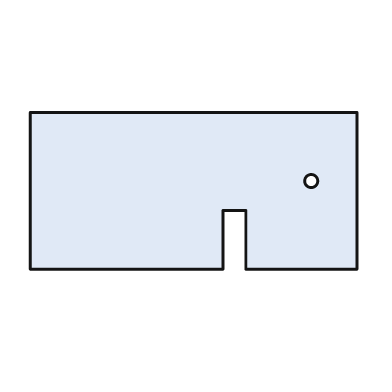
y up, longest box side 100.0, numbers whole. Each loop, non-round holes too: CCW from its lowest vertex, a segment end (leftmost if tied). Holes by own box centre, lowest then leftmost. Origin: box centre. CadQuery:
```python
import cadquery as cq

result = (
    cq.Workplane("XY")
    .moveTo(-50.0, -24.0)
    .lineTo(9.0, -24.0)
    .lineTo(9.0, -6.0)
    .lineTo(16.0, -6.0)
    .lineTo(16.0, -24.0)
    .lineTo(50.0, -24.0)
    .lineTo(50.0, 24.0)
    .lineTo(-50.0, 24.0)
    .close()
    .moveTo(36.0, 3.0)
    .circle(2.0)
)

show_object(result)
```